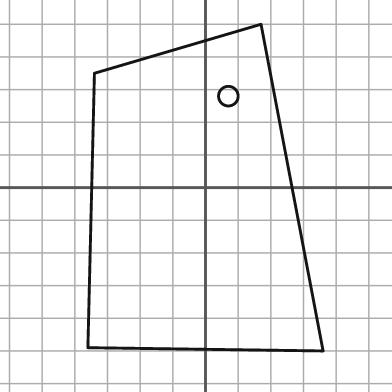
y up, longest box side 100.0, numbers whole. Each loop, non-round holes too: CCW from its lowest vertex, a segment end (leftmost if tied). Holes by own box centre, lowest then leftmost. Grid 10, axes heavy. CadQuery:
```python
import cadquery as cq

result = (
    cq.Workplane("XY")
    .moveTo(36.0, -50.0)
    .lineTo(17.0, 50.0)
    .lineTo(-34.0, 35.0)
    .lineTo(-36.0, -49.0)
    .close()
    .moveTo(7.0, 28.0)
    .circle(3.0)
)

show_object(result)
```